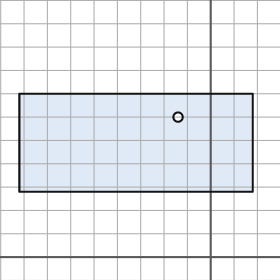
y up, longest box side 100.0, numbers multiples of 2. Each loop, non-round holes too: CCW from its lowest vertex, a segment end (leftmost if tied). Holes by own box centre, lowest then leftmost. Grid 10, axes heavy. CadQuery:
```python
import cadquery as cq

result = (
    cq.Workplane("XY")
    .moveTo(-82.0, 28.0)
    .lineTo(18.0, 28.0)
    .lineTo(18.0, 70.0)
    .lineTo(-82.0, 70.0)
    .close()
    .moveTo(-14.0, 60.0)
    .circle(2.0)
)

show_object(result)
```